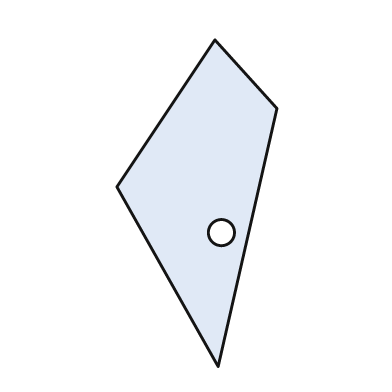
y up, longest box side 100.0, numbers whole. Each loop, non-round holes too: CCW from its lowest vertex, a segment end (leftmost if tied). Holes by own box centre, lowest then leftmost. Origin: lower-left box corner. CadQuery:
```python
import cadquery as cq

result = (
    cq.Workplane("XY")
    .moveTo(31.0, 0.0)
    .lineTo(49.0, 79.0)
    .lineTo(30.0, 100.0)
    .lineTo(0.0, 55.0)
    .close()
    .moveTo(32.0, 41.0)
    .circle(4.0)
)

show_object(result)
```